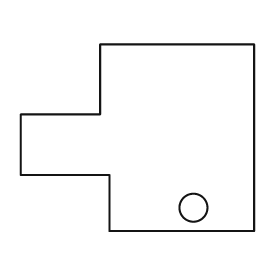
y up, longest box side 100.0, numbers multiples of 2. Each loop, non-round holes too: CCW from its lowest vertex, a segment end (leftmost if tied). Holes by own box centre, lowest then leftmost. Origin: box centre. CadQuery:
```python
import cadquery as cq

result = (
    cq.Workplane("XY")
    .moveTo(-12.0, -40.0)
    .lineTo(50.0, -40.0)
    .lineTo(50.0, 40.0)
    .lineTo(-16.0, 40.0)
    .lineTo(-16.0, 10.0)
    .lineTo(-50.0, 10.0)
    .lineTo(-50.0, -16.0)
    .lineTo(-12.0, -16.0)
    .close()
    .moveTo(24.0, -30.0)
    .circle(6.0)
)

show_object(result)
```